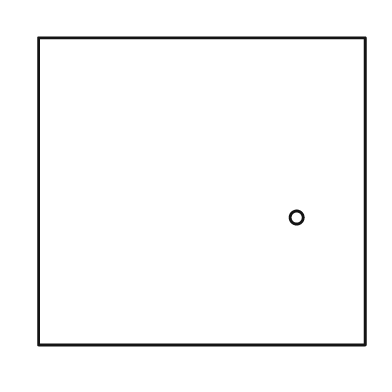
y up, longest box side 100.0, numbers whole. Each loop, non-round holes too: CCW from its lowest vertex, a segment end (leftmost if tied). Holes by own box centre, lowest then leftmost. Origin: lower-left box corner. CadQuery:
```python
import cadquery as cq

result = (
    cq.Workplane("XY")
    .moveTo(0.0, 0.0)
    .lineTo(100.0, 0.0)
    .lineTo(100.0, 94.0)
    .lineTo(0.0, 94.0)
    .close()
    .moveTo(79.0, 39.0)
    .circle(2.0)
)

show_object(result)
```